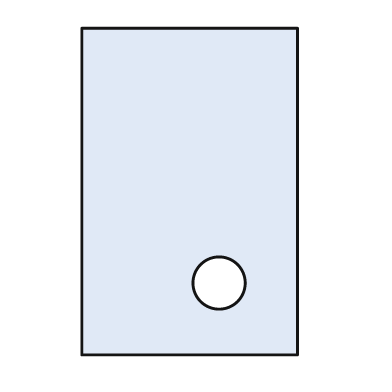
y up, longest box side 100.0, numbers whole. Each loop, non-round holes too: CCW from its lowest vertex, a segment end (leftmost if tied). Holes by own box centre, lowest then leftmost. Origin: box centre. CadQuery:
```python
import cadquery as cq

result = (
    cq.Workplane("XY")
    .moveTo(-33.0, -50.0)
    .lineTo(33.0, -50.0)
    .lineTo(33.0, 50.0)
    .lineTo(-33.0, 50.0)
    .close()
    .moveTo(9.0, -28.0)
    .circle(8.0)
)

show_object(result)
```